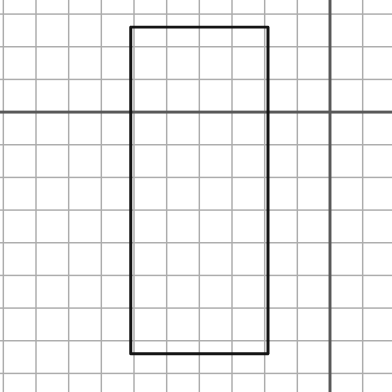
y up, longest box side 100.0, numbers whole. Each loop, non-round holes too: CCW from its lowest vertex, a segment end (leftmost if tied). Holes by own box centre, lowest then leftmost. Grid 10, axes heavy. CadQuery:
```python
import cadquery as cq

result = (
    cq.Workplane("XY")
    .moveTo(-61.0, -74.0)
    .lineTo(-19.0, -74.0)
    .lineTo(-19.0, 26.0)
    .lineTo(-61.0, 26.0)
    .close()
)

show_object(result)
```